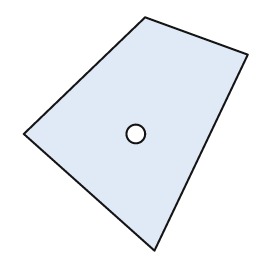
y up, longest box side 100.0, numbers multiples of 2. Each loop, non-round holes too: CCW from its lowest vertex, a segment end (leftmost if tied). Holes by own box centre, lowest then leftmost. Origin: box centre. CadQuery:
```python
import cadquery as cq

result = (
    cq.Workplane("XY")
    .moveTo(8.0, -50.0)
    .lineTo(48.0, 34.0)
    .lineTo(4.0, 50.0)
    .lineTo(-48.0, 0.0)
    .close()
    .moveTo(0.0, 0.0)
    .circle(4.0)
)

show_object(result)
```